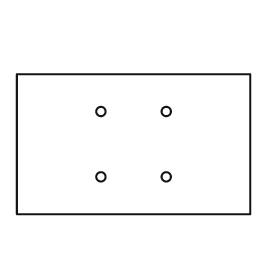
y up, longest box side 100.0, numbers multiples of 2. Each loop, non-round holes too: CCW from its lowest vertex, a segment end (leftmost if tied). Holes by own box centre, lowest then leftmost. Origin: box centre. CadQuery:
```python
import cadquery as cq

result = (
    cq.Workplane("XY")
    .moveTo(-50.0, -30.0)
    .lineTo(50.0, -30.0)
    .lineTo(50.0, 30.0)
    .lineTo(-50.0, 30.0)
    .close()
    .moveTo(-14.0, -14.0)
    .circle(2.0)
    .moveTo(14.0, -14.0)
    .circle(2.0)
    .moveTo(-14.0, 14.0)
    .circle(2.0)
    .moveTo(14.0, 14.0)
    .circle(2.0)
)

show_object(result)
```